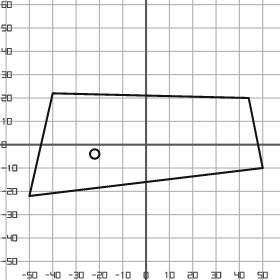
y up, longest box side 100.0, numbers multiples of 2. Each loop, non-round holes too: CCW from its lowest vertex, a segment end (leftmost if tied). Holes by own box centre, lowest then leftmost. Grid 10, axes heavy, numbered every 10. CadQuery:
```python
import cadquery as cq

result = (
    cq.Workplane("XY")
    .moveTo(-50.0, -22.0)
    .lineTo(50.0, -10.0)
    .lineTo(44.0, 20.0)
    .lineTo(-40.0, 22.0)
    .close()
    .moveTo(-22.0, -4.0)
    .circle(2.0)
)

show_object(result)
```